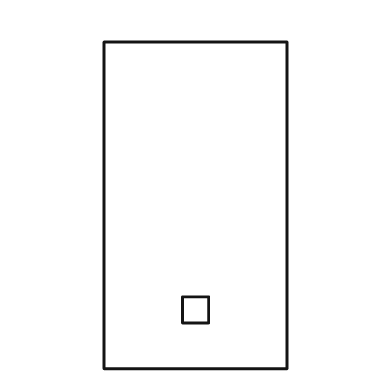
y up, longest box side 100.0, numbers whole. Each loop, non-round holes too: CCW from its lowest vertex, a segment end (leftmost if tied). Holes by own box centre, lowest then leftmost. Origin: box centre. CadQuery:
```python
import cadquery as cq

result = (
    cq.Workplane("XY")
    .moveTo(-28.0, -50.0)
    .lineTo(28.0, -50.0)
    .lineTo(28.0, 50.0)
    .lineTo(-28.0, 50.0)
    .close()
    .moveTo(-4.0, -36.0)
    .lineTo(4.0, -36.0)
    .lineTo(4.0, -28.0)
    .lineTo(-4.0, -28.0)
    .close()
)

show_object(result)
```